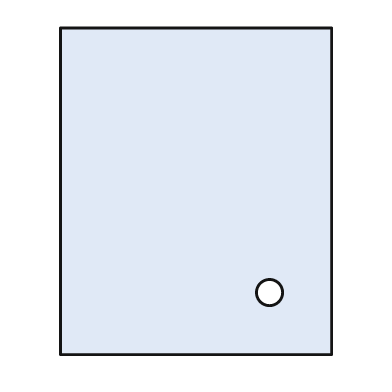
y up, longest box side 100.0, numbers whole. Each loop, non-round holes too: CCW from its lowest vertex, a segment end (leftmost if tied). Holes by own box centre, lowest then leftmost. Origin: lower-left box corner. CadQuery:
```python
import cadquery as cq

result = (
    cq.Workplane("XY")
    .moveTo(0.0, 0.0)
    .lineTo(83.0, 0.0)
    .lineTo(83.0, 100.0)
    .lineTo(0.0, 100.0)
    .close()
    .moveTo(64.0, 19.0)
    .circle(4.0)
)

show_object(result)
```